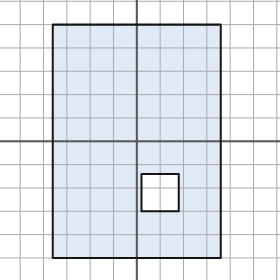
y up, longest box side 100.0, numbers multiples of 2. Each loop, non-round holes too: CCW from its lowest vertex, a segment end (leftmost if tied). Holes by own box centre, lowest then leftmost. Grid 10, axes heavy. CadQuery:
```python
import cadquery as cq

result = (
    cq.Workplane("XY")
    .moveTo(-36.0, -50.0)
    .lineTo(36.0, -50.0)
    .lineTo(36.0, 50.0)
    .lineTo(-36.0, 50.0)
    .close()
    .moveTo(2.0, -30.0)
    .lineTo(18.0, -30.0)
    .lineTo(18.0, -14.0)
    .lineTo(2.0, -14.0)
    .close()
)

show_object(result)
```